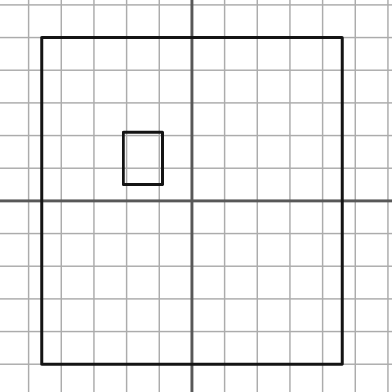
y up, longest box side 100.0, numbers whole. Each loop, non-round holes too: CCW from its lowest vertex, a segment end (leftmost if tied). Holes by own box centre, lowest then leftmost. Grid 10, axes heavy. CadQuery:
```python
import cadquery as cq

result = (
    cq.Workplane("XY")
    .moveTo(-46.0, -50.0)
    .lineTo(46.0, -50.0)
    .lineTo(46.0, 50.0)
    .lineTo(-46.0, 50.0)
    .close()
    .moveTo(-21.0, 5.0)
    .lineTo(-9.0, 5.0)
    .lineTo(-9.0, 21.0)
    .lineTo(-21.0, 21.0)
    .close()
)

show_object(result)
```